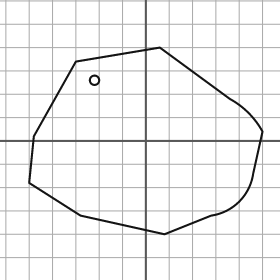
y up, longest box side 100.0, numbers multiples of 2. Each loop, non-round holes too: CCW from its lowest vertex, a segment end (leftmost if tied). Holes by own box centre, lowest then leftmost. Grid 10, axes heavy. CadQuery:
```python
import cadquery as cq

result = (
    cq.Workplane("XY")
    .moveTo(8.0, -40.0)
    .lineTo(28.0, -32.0)
    .threePointArc((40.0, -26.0), (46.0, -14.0))
    .lineTo(50.0, 4.0)
    .threePointArc((44.0, 12.0), (36.0, 18.0))
    .lineTo(6.0, 40.0)
    .lineTo(-30.0, 34.0)
    .lineTo(-48.0, 2.0)
    .lineTo(-50.0, -18.0)
    .lineTo(-28.0, -32.0)
    .close()
    .moveTo(-22.0, 26.0)
    .circle(2.0)
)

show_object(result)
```